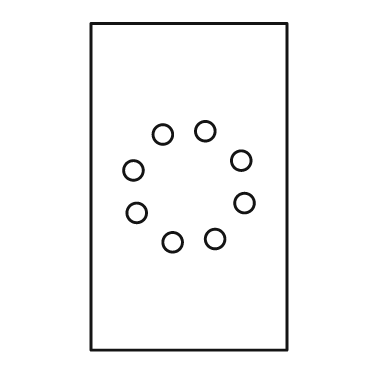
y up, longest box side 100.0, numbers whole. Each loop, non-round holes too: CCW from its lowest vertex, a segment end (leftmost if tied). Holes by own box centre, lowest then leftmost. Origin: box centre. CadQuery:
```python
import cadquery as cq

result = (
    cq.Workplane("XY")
    .moveTo(-30.0, -50.0)
    .lineTo(30.0, -50.0)
    .lineTo(30.0, 50.0)
    .lineTo(-30.0, 50.0)
    .close()
    .moveTo(-5.0, -17.0)
    .circle(3.0)
    .moveTo(8.0, -16.0)
    .circle(3.0)
    .moveTo(-16.0, -8.0)
    .circle(3.0)
    .moveTo(17.0, -5.0)
    .circle(3.0)
    .moveTo(-17.0, 5.0)
    .circle(3.0)
    .moveTo(16.0, 8.0)
    .circle(3.0)
    .moveTo(-8.0, 16.0)
    .circle(3.0)
    .moveTo(5.0, 17.0)
    .circle(3.0)
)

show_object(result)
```